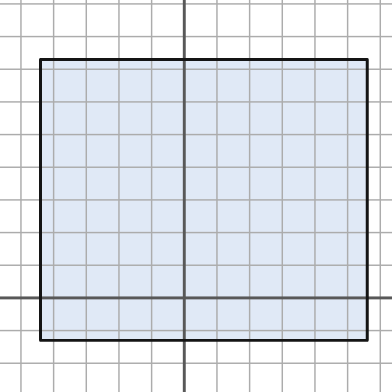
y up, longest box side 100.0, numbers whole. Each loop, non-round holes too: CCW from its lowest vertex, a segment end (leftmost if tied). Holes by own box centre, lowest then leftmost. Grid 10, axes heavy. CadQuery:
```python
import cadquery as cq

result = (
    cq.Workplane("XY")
    .moveTo(-44.0, -13.0)
    .lineTo(56.0, -13.0)
    .lineTo(56.0, 73.0)
    .lineTo(-44.0, 73.0)
    .close()
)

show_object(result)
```